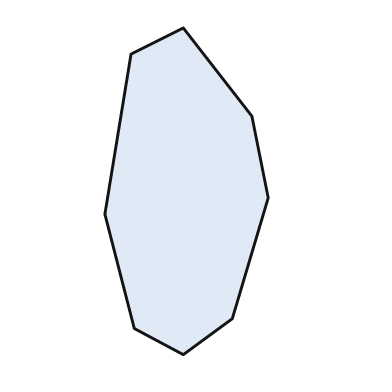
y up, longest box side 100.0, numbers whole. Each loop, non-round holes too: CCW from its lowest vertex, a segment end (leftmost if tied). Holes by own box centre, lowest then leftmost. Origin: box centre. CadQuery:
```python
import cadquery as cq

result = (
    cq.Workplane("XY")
    .moveTo(-1.0, -50.0)
    .lineTo(14.0, -39.0)
    .lineTo(25.0, -2.0)
    .lineTo(20.0, 23.0)
    .lineTo(-1.0, 50.0)
    .lineTo(-17.0, 42.0)
    .lineTo(-25.0, -7.0)
    .lineTo(-16.0, -42.0)
    .close()
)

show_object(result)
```